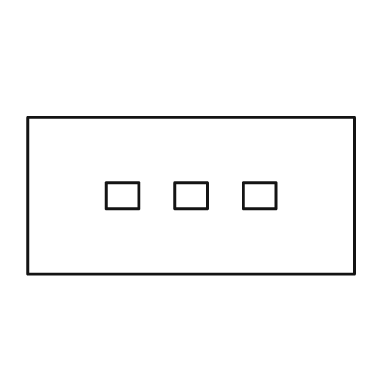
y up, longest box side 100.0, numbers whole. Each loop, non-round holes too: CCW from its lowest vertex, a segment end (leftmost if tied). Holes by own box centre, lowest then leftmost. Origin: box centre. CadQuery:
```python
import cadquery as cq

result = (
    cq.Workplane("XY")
    .moveTo(-50.0, -24.0)
    .lineTo(50.0, -24.0)
    .lineTo(50.0, 24.0)
    .lineTo(-50.0, 24.0)
    .close()
    .moveTo(-26.0, -4.0)
    .lineTo(-16.0, -4.0)
    .lineTo(-16.0, 4.0)
    .lineTo(-26.0, 4.0)
    .close()
    .moveTo(-5.0, -4.0)
    .lineTo(5.0, -4.0)
    .lineTo(5.0, 4.0)
    .lineTo(-5.0, 4.0)
    .close()
    .moveTo(16.0, -4.0)
    .lineTo(26.0, -4.0)
    .lineTo(26.0, 4.0)
    .lineTo(16.0, 4.0)
    .close()
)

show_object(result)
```